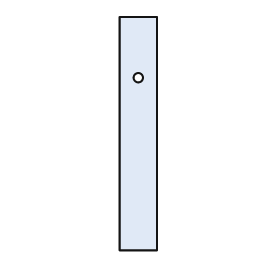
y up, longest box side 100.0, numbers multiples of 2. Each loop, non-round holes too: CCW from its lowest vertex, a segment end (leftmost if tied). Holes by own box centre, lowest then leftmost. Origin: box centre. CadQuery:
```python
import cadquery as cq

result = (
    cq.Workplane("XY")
    .moveTo(-8.0, -50.0)
    .lineTo(8.0, -50.0)
    .lineTo(8.0, 50.0)
    .lineTo(-8.0, 50.0)
    .close()
    .moveTo(0.0, 24.0)
    .circle(2.0)
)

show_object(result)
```